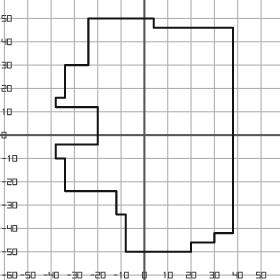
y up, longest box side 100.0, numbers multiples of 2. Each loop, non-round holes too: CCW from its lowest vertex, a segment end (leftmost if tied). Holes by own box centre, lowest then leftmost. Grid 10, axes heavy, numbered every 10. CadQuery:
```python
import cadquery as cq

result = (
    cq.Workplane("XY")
    .moveTo(-8.0, -50.0)
    .lineTo(20.0, -50.0)
    .lineTo(20.0, -46.0)
    .lineTo(30.0, -46.0)
    .lineTo(30.0, -42.0)
    .lineTo(38.0, -42.0)
    .lineTo(38.0, 46.0)
    .lineTo(4.0, 46.0)
    .lineTo(4.0, 50.0)
    .lineTo(-24.0, 50.0)
    .lineTo(-24.0, 30.0)
    .lineTo(-34.0, 30.0)
    .lineTo(-34.0, 16.0)
    .lineTo(-38.0, 16.0)
    .lineTo(-38.0, 12.0)
    .lineTo(-20.0, 12.0)
    .lineTo(-20.0, -4.0)
    .lineTo(-38.0, -4.0)
    .lineTo(-38.0, -10.0)
    .lineTo(-34.0, -10.0)
    .lineTo(-34.0, -24.0)
    .lineTo(-12.0, -24.0)
    .lineTo(-12.0, -34.0)
    .lineTo(-8.0, -34.0)
    .close()
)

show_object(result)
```